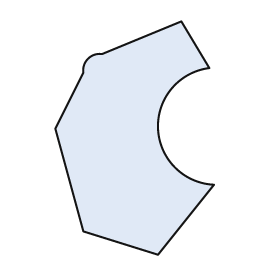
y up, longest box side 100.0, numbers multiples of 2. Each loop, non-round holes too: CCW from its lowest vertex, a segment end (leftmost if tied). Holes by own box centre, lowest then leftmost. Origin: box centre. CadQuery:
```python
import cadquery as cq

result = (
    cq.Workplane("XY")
    .moveTo(10.0, -50.0)
    .lineTo(34.0, -20.0)
    .threePointArc((10.0, 4.0), (32.0, 30.0))
    .lineTo(20.0, 50.0)
    .lineTo(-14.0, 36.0)
    .threePointArc((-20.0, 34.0), (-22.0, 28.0))
    .lineTo(-34.0, 4.0)
    .lineTo(-22.0, -40.0)
    .close()
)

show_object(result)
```